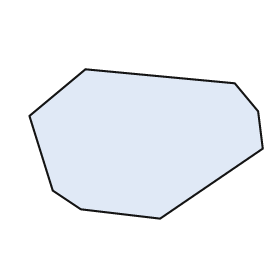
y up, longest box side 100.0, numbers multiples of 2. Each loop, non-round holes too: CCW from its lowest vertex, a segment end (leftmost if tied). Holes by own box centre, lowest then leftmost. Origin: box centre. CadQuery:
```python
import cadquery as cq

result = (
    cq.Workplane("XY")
    .moveTo(6.0, -32.0)
    .lineTo(50.0, -2.0)
    .lineTo(48.0, 14.0)
    .lineTo(38.0, 26.0)
    .lineTo(-26.0, 32.0)
    .lineTo(-50.0, 12.0)
    .lineTo(-40.0, -20.0)
    .lineTo(-28.0, -28.0)
    .close()
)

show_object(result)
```